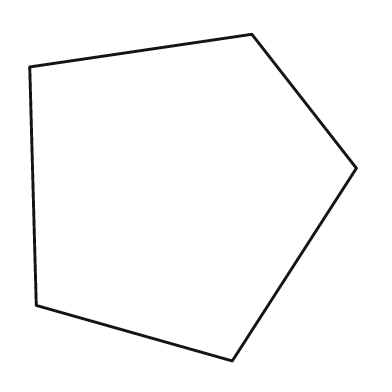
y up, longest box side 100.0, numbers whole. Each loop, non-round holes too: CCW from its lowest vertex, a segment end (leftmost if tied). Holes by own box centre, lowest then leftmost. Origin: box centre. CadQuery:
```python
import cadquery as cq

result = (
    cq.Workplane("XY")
    .moveTo(12.0, -50.0)
    .lineTo(50.0, 9.0)
    .lineTo(18.0, 50.0)
    .lineTo(-50.0, 40.0)
    .lineTo(-48.0, -33.0)
    .close()
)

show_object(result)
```